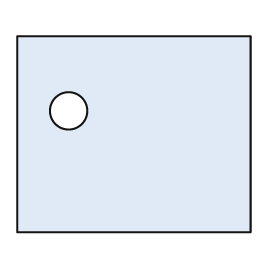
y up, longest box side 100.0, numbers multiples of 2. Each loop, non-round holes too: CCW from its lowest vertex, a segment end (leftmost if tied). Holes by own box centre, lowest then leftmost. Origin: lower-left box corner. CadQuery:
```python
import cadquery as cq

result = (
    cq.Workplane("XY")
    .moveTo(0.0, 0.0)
    .lineTo(100.0, 0.0)
    .lineTo(100.0, 84.0)
    .lineTo(0.0, 84.0)
    .close()
    .moveTo(22.0, 52.0)
    .circle(8.0)
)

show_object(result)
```